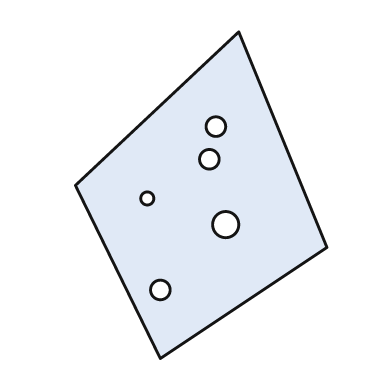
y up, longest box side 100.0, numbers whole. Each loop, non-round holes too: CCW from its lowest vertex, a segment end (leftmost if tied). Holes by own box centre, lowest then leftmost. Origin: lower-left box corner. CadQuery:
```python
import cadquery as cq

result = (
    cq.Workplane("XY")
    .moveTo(26.0, 0.0)
    .lineTo(77.0, 34.0)
    .lineTo(50.0, 100.0)
    .lineTo(0.0, 53.0)
    .close()
    .moveTo(26.0, 21.0)
    .circle(3.0)
    .moveTo(46.0, 41.0)
    .circle(4.0)
    .moveTo(22.0, 49.0)
    .circle(2.0)
    .moveTo(41.0, 61.0)
    .circle(3.0)
    .moveTo(43.0, 71.0)
    .circle(3.0)
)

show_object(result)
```